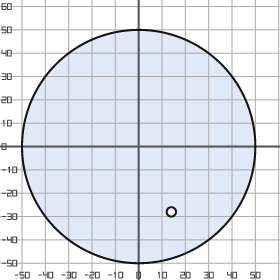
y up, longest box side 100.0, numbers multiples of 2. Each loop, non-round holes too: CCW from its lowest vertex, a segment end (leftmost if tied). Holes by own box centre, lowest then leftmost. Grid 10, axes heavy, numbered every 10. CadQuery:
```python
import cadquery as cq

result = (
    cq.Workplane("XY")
    .moveTo(0.0, 0.0)
    .circle(50.0)
    .moveTo(14.0, -28.0)
    .circle(2.0)
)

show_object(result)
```